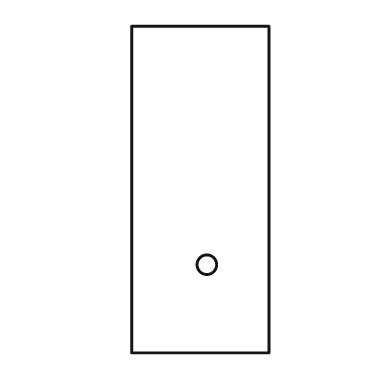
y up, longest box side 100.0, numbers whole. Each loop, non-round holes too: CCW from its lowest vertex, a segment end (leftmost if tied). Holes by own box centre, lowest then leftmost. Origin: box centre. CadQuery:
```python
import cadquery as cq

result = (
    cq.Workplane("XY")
    .moveTo(-21.0, -50.0)
    .lineTo(21.0, -50.0)
    .lineTo(21.0, 50.0)
    .lineTo(-21.0, 50.0)
    .close()
    .moveTo(2.0, -23.0)
    .circle(3.0)
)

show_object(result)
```